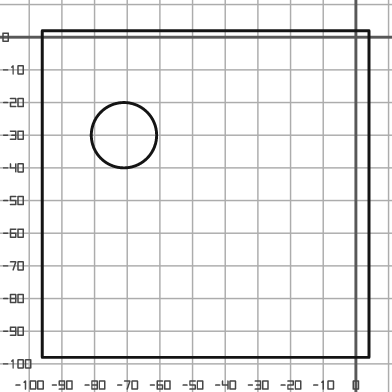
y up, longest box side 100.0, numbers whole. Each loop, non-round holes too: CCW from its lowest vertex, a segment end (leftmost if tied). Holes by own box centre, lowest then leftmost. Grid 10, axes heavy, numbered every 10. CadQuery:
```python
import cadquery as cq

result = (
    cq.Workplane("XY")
    .moveTo(-96.0, -98.0)
    .lineTo(4.0, -98.0)
    .lineTo(4.0, 2.0)
    .lineTo(-96.0, 2.0)
    .close()
    .moveTo(-71.0, -30.0)
    .circle(10.0)
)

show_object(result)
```